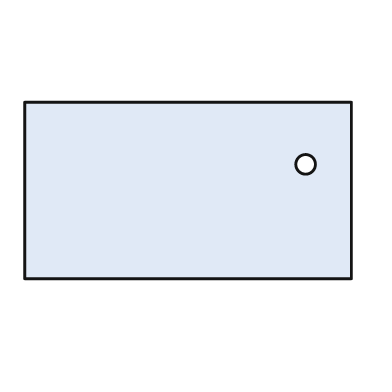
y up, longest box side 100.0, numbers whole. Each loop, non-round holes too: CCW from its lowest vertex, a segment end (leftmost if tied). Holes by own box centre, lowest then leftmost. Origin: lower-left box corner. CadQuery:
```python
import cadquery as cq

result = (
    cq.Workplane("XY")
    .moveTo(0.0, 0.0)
    .lineTo(100.0, 0.0)
    .lineTo(100.0, 54.0)
    .lineTo(0.0, 54.0)
    .close()
    .moveTo(86.0, 35.0)
    .circle(3.0)
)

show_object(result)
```